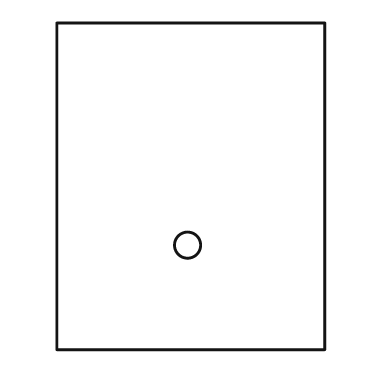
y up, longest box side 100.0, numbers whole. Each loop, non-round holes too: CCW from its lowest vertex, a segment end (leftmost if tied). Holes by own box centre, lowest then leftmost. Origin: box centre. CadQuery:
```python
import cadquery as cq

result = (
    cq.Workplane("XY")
    .moveTo(-41.0, -50.0)
    .lineTo(41.0, -50.0)
    .lineTo(41.0, 50.0)
    .lineTo(-41.0, 50.0)
    .close()
    .moveTo(-1.0, -18.0)
    .circle(4.0)
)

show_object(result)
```